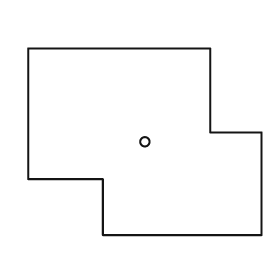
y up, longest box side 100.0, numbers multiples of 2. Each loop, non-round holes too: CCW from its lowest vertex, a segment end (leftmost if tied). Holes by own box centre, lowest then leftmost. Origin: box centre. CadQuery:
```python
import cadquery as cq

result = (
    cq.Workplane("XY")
    .moveTo(-18.0, -40.0)
    .lineTo(50.0, -40.0)
    .lineTo(50.0, 4.0)
    .lineTo(28.0, 4.0)
    .lineTo(28.0, 40.0)
    .lineTo(-50.0, 40.0)
    .lineTo(-50.0, -16.0)
    .lineTo(-18.0, -16.0)
    .close()
    .moveTo(0.0, 0.0)
    .circle(2.0)
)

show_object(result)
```